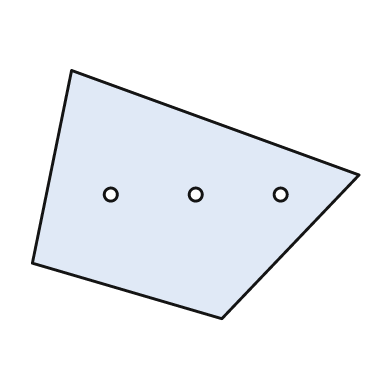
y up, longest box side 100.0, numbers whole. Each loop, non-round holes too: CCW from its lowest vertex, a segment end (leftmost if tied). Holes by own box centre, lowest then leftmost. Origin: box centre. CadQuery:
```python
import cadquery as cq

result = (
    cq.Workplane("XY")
    .moveTo(8.0, -38.0)
    .lineTo(50.0, 6.0)
    .lineTo(-38.0, 38.0)
    .lineTo(-50.0, -21.0)
    .close()
    .moveTo(-26.0, 0.0)
    .circle(2.0)
    .moveTo(0.0, 0.0)
    .circle(2.0)
    .moveTo(26.0, 0.0)
    .circle(2.0)
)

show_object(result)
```